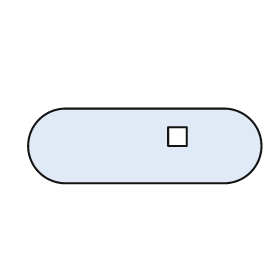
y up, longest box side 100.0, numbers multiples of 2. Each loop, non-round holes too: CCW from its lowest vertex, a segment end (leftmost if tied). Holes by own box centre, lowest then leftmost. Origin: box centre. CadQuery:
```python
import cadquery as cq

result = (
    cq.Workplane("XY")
    .moveTo(-34.0, -16.0)
    .lineTo(34.0, -16.0)
    .threePointArc((50.0, 0.0), (34.0, 16.0))
    .lineTo(-34.0, 16.0)
    .threePointArc((-50.0, 0.0), (-34.0, -16.0))
    .close()
    .moveTo(10.0, 0.0)
    .lineTo(18.0, 0.0)
    .lineTo(18.0, 8.0)
    .lineTo(10.0, 8.0)
    .close()
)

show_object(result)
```